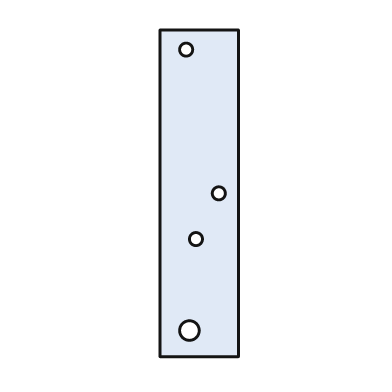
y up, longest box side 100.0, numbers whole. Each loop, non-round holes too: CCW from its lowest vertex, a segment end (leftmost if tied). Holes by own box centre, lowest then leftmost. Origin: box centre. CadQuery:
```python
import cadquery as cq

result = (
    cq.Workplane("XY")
    .moveTo(-12.0, -50.0)
    .lineTo(12.0, -50.0)
    .lineTo(12.0, 50.0)
    .lineTo(-12.0, 50.0)
    .close()
    .moveTo(-3.0, -42.0)
    .circle(3.0)
    .moveTo(-1.0, -14.0)
    .circle(2.0)
    .moveTo(6.0, 0.0)
    .circle(2.0)
    .moveTo(-4.0, 44.0)
    .circle(2.0)
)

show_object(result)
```